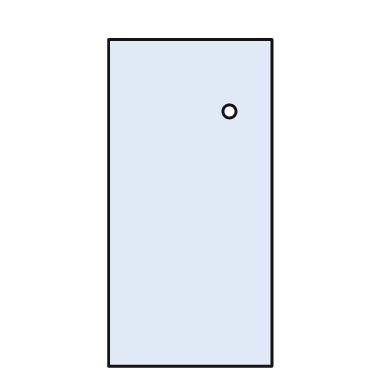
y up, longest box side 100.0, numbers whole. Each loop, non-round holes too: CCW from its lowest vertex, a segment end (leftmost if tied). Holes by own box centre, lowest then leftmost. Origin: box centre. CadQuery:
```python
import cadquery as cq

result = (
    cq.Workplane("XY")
    .moveTo(-25.0, -50.0)
    .lineTo(25.0, -50.0)
    .lineTo(25.0, 50.0)
    .lineTo(-25.0, 50.0)
    .close()
    .moveTo(12.0, 28.0)
    .circle(2.0)
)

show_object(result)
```